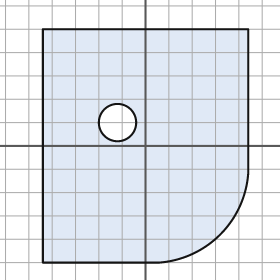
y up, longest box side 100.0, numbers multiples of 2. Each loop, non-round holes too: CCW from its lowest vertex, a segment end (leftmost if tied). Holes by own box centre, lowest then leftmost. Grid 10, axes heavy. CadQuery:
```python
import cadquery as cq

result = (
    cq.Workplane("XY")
    .moveTo(-44.0, -50.0)
    .lineTo(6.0, -50.0)
    .threePointArc((32.0, -38.0), (44.0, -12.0))
    .lineTo(44.0, 50.0)
    .lineTo(-44.0, 50.0)
    .close()
    .moveTo(-12.0, 10.0)
    .circle(8.0)
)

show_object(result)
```